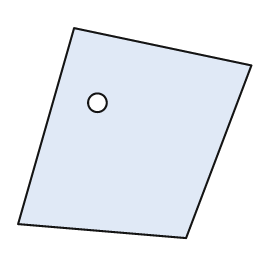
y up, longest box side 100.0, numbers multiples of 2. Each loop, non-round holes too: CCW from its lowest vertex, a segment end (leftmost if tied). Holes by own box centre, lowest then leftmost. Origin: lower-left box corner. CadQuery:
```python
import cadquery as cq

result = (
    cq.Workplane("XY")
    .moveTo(72.0, 0.0)
    .lineTo(100.0, 74.0)
    .lineTo(24.0, 90.0)
    .lineTo(0.0, 6.0)
    .close()
    .moveTo(34.0, 58.0)
    .circle(4.0)
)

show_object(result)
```